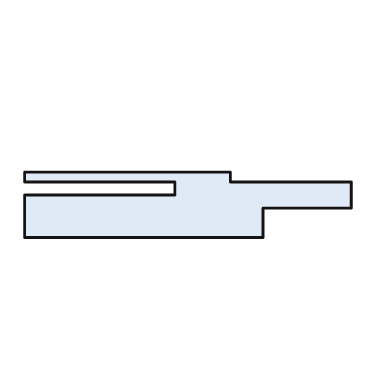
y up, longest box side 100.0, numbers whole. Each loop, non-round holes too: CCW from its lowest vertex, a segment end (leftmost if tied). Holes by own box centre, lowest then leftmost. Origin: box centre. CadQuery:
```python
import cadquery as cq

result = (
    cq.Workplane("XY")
    .moveTo(-50.0, -10.0)
    .lineTo(23.0, -10.0)
    .lineTo(23.0, -1.0)
    .lineTo(50.0, -1.0)
    .lineTo(50.0, 7.0)
    .lineTo(13.0, 7.0)
    .lineTo(13.0, 10.0)
    .lineTo(-50.0, 10.0)
    .lineTo(-50.0, 7.0)
    .lineTo(-4.0, 7.0)
    .lineTo(-4.0, 3.0)
    .lineTo(-50.0, 3.0)
    .close()
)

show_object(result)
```